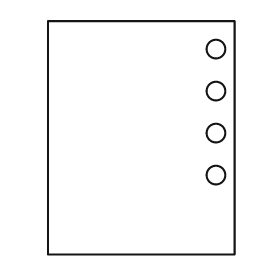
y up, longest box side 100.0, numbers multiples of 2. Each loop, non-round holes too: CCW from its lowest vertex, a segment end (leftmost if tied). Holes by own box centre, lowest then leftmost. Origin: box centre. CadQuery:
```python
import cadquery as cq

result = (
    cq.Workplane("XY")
    .moveTo(-40.0, -50.0)
    .lineTo(40.0, -50.0)
    .lineTo(40.0, 50.0)
    .lineTo(-40.0, 50.0)
    .close()
    .moveTo(32.0, -16.0)
    .circle(4.0)
    .moveTo(32.0, 2.0)
    .circle(4.0)
    .moveTo(32.0, 20.0)
    .circle(4.0)
    .moveTo(32.0, 38.0)
    .circle(4.0)
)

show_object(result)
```